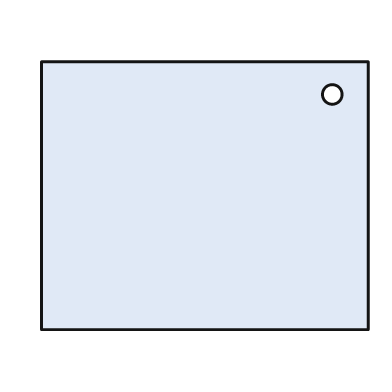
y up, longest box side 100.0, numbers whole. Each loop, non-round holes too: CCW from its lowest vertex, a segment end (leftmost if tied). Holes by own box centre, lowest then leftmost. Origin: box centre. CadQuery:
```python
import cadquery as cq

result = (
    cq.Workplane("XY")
    .moveTo(-50.0, -41.0)
    .lineTo(50.0, -41.0)
    .lineTo(50.0, 41.0)
    .lineTo(-50.0, 41.0)
    .close()
    .moveTo(39.0, 31.0)
    .circle(3.0)
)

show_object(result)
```